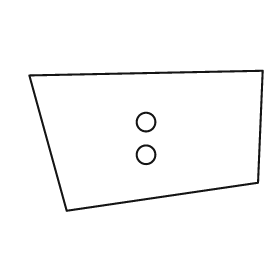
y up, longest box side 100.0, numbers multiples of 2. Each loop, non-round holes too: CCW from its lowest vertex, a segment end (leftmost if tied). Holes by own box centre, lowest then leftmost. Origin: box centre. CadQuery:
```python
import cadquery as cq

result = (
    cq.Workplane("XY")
    .moveTo(-34.0, -30.0)
    .lineTo(48.0, -18.0)
    .lineTo(50.0, 30.0)
    .lineTo(-50.0, 28.0)
    .close()
    .moveTo(0.0, -6.0)
    .circle(4.0)
    .moveTo(0.0, 8.0)
    .circle(4.0)
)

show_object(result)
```